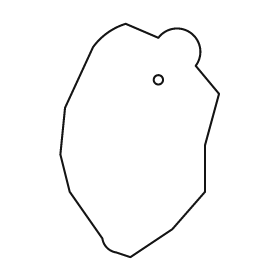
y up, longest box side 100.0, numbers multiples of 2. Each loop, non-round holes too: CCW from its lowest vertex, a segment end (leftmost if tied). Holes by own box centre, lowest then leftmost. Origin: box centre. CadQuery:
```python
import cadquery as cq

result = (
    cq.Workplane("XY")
    .moveTo(-4.0, -50.0)
    .lineTo(14.0, -38.0)
    .lineTo(28.0, -22.0)
    .lineTo(28.0, -2.0)
    .lineTo(34.0, 20.0)
    .lineTo(24.0, 32.0)
    .threePointArc((22.0, 46.0), (8.0, 44.0))
    .lineTo(-6.0, 50.0)
    .threePointArc((-14.0, 46.0), (-20.0, 40.0))
    .lineTo(-32.0, 14.0)
    .lineTo(-34.0, -6.0)
    .lineTo(-30.0, -22.0)
    .lineTo(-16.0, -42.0)
    .threePointArc((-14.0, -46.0), (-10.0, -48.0))
    .close()
    .moveTo(8.0, 26.0)
    .circle(2.0)
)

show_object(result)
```